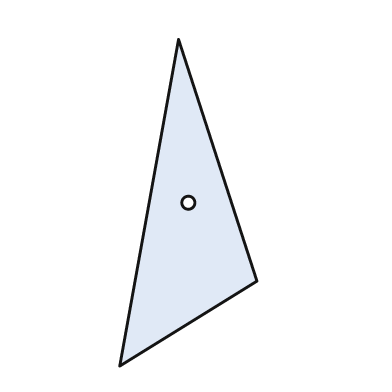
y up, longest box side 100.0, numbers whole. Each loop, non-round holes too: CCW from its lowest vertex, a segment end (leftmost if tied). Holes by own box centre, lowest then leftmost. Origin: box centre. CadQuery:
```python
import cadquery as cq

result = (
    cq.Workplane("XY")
    .moveTo(-21.0, -50.0)
    .lineTo(21.0, -24.0)
    .lineTo(-3.0, 50.0)
    .close()
    .moveTo(0.0, 0.0)
    .circle(2.0)
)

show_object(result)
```